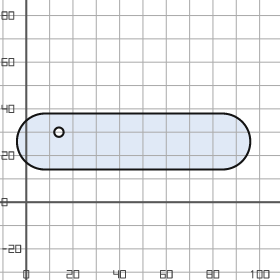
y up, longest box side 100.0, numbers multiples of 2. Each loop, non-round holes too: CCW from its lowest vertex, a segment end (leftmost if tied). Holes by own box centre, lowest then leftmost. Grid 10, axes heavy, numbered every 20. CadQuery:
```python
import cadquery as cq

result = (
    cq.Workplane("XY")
    .moveTo(8.0, 14.0)
    .lineTo(84.0, 14.0)
    .threePointArc((96.0, 26.0), (84.0, 38.0))
    .lineTo(8.0, 38.0)
    .threePointArc((-4.0, 26.0), (8.0, 14.0))
    .close()
    .moveTo(14.0, 30.0)
    .circle(2.0)
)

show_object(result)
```